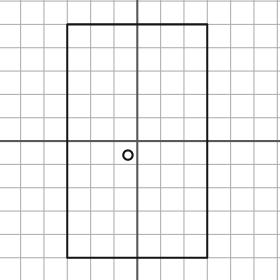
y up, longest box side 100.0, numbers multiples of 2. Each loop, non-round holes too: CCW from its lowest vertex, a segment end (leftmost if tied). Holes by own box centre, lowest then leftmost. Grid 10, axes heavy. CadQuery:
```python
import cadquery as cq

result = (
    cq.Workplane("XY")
    .moveTo(-30.0, -50.0)
    .lineTo(30.0, -50.0)
    .lineTo(30.0, 50.0)
    .lineTo(-30.0, 50.0)
    .close()
    .moveTo(-4.0, -6.0)
    .circle(2.0)
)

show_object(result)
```